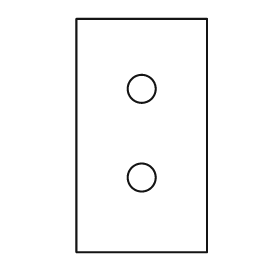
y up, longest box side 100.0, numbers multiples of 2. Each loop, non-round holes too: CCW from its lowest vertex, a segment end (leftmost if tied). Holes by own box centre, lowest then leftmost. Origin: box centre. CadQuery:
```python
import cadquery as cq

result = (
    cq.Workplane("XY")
    .moveTo(-28.0, -50.0)
    .lineTo(28.0, -50.0)
    .lineTo(28.0, 50.0)
    .lineTo(-28.0, 50.0)
    .close()
    .moveTo(0.0, -18.0)
    .circle(6.0)
    .moveTo(0.0, 20.0)
    .circle(6.0)
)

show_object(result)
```